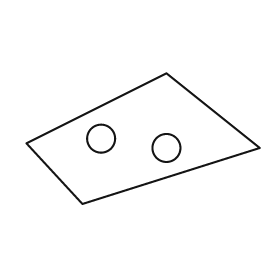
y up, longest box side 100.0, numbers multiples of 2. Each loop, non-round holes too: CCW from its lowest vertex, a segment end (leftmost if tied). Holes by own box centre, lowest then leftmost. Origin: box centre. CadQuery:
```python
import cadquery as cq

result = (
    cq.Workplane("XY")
    .moveTo(-26.0, -28.0)
    .lineTo(50.0, -4.0)
    .lineTo(10.0, 28.0)
    .lineTo(-50.0, -2.0)
    .close()
    .moveTo(10.0, -4.0)
    .circle(6.0)
    .moveTo(-18.0, 0.0)
    .circle(6.0)
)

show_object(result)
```